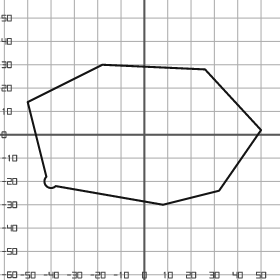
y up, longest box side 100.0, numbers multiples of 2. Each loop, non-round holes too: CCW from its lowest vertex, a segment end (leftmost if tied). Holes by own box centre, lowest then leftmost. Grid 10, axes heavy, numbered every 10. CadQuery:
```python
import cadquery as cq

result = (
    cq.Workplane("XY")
    .moveTo(8.0, -30.0)
    .lineTo(32.0, -24.0)
    .lineTo(50.0, 2.0)
    .lineTo(26.0, 28.0)
    .lineTo(-18.0, 30.0)
    .lineTo(-50.0, 14.0)
    .lineTo(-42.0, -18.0)
    .threePointArc((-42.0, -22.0), (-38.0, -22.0))
    .close()
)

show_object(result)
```